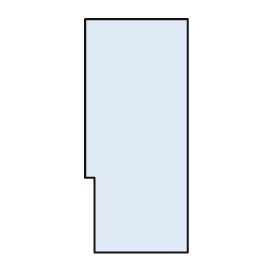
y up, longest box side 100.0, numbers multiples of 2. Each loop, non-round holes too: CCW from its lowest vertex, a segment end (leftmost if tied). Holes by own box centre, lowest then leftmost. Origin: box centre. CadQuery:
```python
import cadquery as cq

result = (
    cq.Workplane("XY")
    .moveTo(-18.0, -50.0)
    .lineTo(22.0, -50.0)
    .lineTo(22.0, 50.0)
    .lineTo(-22.0, 50.0)
    .lineTo(-22.0, -18.0)
    .lineTo(-18.0, -18.0)
    .close()
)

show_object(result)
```